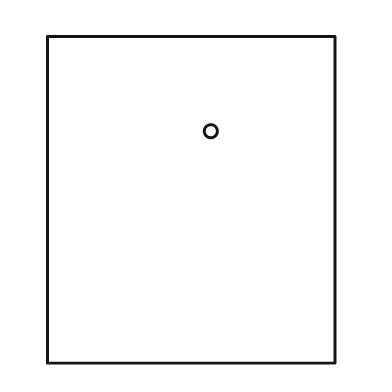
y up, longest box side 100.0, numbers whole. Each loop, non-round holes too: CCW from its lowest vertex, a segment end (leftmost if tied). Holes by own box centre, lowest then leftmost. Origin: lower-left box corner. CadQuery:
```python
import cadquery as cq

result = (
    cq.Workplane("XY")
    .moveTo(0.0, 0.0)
    .lineTo(88.0, 0.0)
    .lineTo(88.0, 100.0)
    .lineTo(0.0, 100.0)
    .close()
    .moveTo(50.0, 71.0)
    .circle(2.0)
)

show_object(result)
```